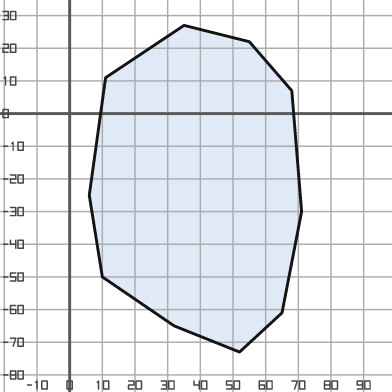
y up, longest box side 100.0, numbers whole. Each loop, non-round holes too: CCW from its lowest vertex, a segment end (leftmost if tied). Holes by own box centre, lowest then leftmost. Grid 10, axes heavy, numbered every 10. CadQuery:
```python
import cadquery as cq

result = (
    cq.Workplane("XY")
    .moveTo(52.0, -73.0)
    .lineTo(65.0, -61.0)
    .lineTo(71.0, -30.0)
    .lineTo(68.0, 7.0)
    .lineTo(55.0, 22.0)
    .lineTo(35.0, 27.0)
    .lineTo(11.0, 11.0)
    .lineTo(6.0, -25.0)
    .lineTo(10.0, -50.0)
    .lineTo(32.0, -65.0)
    .close()
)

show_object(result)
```